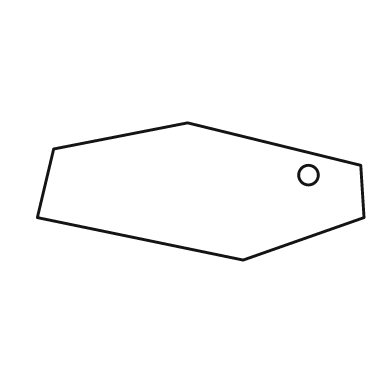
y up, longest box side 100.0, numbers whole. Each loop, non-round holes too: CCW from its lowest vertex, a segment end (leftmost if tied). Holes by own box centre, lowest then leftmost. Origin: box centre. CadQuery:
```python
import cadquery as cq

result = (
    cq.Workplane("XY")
    .moveTo(13.0, -21.0)
    .lineTo(50.0, -8.0)
    .lineTo(49.0, 8.0)
    .lineTo(-4.0, 21.0)
    .lineTo(-45.0, 13.0)
    .lineTo(-50.0, -8.0)
    .close()
    .moveTo(33.0, 5.0)
    .circle(3.0)
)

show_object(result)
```